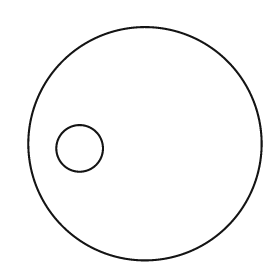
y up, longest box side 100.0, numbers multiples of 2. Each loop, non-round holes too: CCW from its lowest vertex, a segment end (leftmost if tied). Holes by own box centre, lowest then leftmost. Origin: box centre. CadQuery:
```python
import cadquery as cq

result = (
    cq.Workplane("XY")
    .moveTo(0.0, 0.0)
    .circle(50.0)
    .moveTo(-28.0, -2.0)
    .circle(10.0)
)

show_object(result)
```